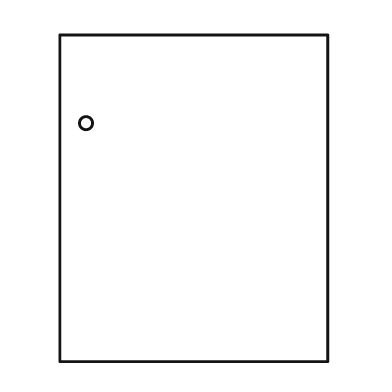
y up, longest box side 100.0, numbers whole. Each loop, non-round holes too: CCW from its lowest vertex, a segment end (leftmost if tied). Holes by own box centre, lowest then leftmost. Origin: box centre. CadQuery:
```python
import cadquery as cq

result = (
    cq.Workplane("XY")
    .moveTo(-41.0, -50.0)
    .lineTo(41.0, -50.0)
    .lineTo(41.0, 50.0)
    .lineTo(-41.0, 50.0)
    .close()
    .moveTo(-33.0, 23.0)
    .circle(2.0)
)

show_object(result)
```